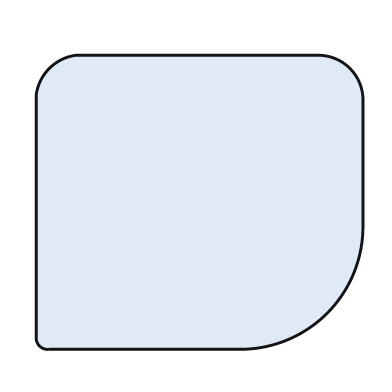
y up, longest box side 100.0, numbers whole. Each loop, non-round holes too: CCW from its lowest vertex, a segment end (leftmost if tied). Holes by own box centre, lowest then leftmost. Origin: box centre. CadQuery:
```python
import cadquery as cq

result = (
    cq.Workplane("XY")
    .moveTo(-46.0, -45.0)
    .lineTo(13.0, -45.0)
    .threePointArc((39.0, -34.0), (50.0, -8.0))
    .lineTo(50.0, 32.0)
    .threePointArc((46.0, 41.0), (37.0, 45.0))
    .lineTo(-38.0, 45.0)
    .threePointArc((-46.0, 41.0), (-50.0, 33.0))
    .lineTo(-50.0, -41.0)
    .threePointArc((-49.0, -44.0), (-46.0, -45.0))
    .close()
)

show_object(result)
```